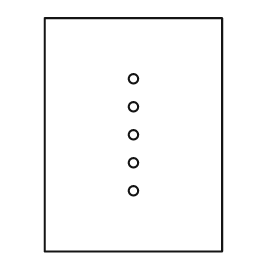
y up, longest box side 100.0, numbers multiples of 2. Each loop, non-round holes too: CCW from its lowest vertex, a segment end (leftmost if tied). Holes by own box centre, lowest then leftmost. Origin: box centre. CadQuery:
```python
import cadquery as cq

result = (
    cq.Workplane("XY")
    .moveTo(-38.0, -50.0)
    .lineTo(38.0, -50.0)
    .lineTo(38.0, 50.0)
    .lineTo(-38.0, 50.0)
    .close()
    .moveTo(0.0, -24.0)
    .circle(2.0)
    .moveTo(0.0, -12.0)
    .circle(2.0)
    .moveTo(0.0, 0.0)
    .circle(2.0)
    .moveTo(0.0, 12.0)
    .circle(2.0)
    .moveTo(0.0, 24.0)
    .circle(2.0)
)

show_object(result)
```